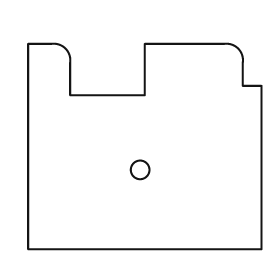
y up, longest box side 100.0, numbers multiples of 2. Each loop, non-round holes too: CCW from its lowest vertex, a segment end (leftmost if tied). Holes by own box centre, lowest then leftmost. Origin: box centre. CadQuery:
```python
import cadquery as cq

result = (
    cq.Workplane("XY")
    .moveTo(-50.0, -44.0)
    .lineTo(50.0, -44.0)
    .lineTo(50.0, 26.0)
    .lineTo(42.0, 26.0)
    .lineTo(42.0, 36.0)
    .threePointArc((40.0, 42.0), (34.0, 44.0))
    .lineTo(0.0, 44.0)
    .lineTo(0.0, 22.0)
    .lineTo(-32.0, 22.0)
    .lineTo(-32.0, 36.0)
    .threePointArc((-34.0, 42.0), (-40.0, 44.0))
    .lineTo(-50.0, 44.0)
    .close()
    .moveTo(-2.0, -10.0)
    .circle(4.0)
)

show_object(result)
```